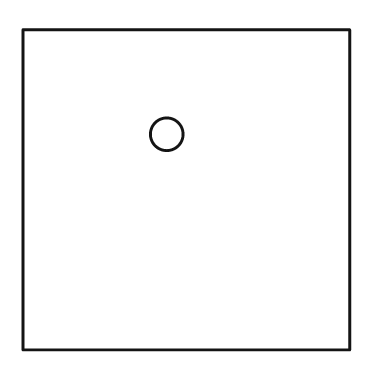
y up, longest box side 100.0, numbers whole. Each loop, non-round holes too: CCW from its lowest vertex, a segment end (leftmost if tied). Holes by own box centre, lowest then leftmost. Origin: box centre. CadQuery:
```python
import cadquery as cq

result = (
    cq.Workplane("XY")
    .moveTo(-50.0, -49.0)
    .lineTo(50.0, -49.0)
    .lineTo(50.0, 49.0)
    .lineTo(-50.0, 49.0)
    .close()
    .moveTo(-6.0, 17.0)
    .circle(5.0)
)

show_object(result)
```